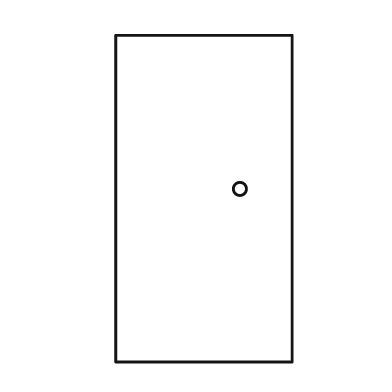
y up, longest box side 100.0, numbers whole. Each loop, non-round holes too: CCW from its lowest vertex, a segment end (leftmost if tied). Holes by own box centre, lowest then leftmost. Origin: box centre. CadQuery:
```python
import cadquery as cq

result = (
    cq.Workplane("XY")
    .moveTo(-27.0, -50.0)
    .lineTo(27.0, -50.0)
    .lineTo(27.0, 50.0)
    .lineTo(-27.0, 50.0)
    .close()
    .moveTo(11.0, 3.0)
    .circle(2.0)
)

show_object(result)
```